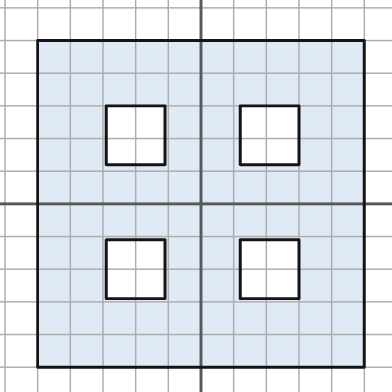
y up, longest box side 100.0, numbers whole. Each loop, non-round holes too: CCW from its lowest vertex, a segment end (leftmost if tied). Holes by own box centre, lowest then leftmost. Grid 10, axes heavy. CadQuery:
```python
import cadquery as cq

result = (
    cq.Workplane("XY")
    .moveTo(-50.0, -50.0)
    .lineTo(50.0, -50.0)
    .lineTo(50.0, 50.0)
    .lineTo(-50.0, 50.0)
    .close()
    .moveTo(-29.0, -29.0)
    .lineTo(-11.0, -29.0)
    .lineTo(-11.0, -11.0)
    .lineTo(-29.0, -11.0)
    .close()
    .moveTo(12.0, -29.0)
    .lineTo(30.0, -29.0)
    .lineTo(30.0, -11.0)
    .lineTo(12.0, -11.0)
    .close()
    .moveTo(-29.0, 12.0)
    .lineTo(-11.0, 12.0)
    .lineTo(-11.0, 30.0)
    .lineTo(-29.0, 30.0)
    .close()
    .moveTo(12.0, 12.0)
    .lineTo(30.0, 12.0)
    .lineTo(30.0, 30.0)
    .lineTo(12.0, 30.0)
    .close()
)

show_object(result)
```